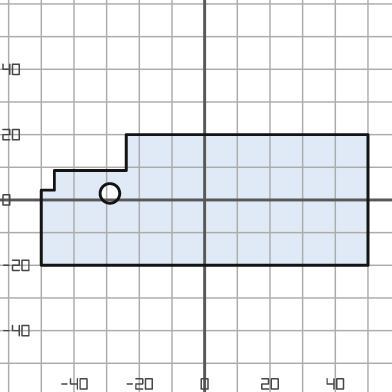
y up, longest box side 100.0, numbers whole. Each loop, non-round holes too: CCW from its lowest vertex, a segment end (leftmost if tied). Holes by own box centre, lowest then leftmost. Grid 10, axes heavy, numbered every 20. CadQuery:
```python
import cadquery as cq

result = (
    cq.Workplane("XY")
    .moveTo(-50.0, -20.0)
    .lineTo(50.0, -20.0)
    .lineTo(50.0, 20.0)
    .lineTo(-24.0, 20.0)
    .lineTo(-24.0, 9.0)
    .lineTo(-46.0, 9.0)
    .lineTo(-46.0, 3.0)
    .lineTo(-50.0, 3.0)
    .close()
    .moveTo(-29.0, 2.0)
    .circle(3.0)
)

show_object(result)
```